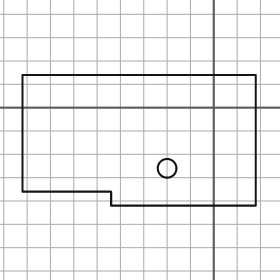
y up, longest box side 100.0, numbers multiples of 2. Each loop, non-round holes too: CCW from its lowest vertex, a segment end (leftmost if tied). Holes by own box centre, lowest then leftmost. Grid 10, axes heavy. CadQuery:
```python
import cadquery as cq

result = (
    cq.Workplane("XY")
    .moveTo(-44.0, -42.0)
    .lineTo(18.0, -42.0)
    .lineTo(18.0, 14.0)
    .lineTo(-82.0, 14.0)
    .lineTo(-82.0, -36.0)
    .lineTo(-44.0, -36.0)
    .close()
    .moveTo(-20.0, -26.0)
    .circle(4.0)
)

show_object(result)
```